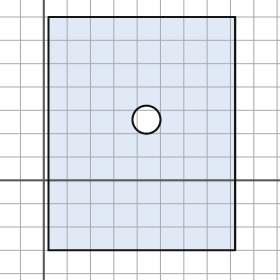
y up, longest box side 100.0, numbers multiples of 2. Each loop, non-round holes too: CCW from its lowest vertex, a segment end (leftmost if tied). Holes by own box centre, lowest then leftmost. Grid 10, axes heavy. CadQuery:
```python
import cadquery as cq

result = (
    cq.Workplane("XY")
    .moveTo(2.0, -30.0)
    .lineTo(82.0, -30.0)
    .lineTo(82.0, 70.0)
    .lineTo(2.0, 70.0)
    .close()
    .moveTo(44.0, 26.0)
    .circle(6.0)
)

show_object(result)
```